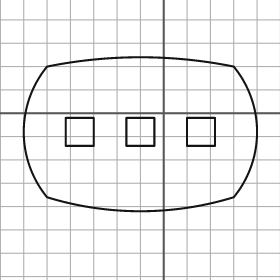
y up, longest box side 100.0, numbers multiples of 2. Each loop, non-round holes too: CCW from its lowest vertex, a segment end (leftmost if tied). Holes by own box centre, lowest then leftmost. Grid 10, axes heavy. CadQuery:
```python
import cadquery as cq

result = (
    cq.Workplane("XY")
    .moveTo(-50.0, -36.0)
    .threePointArc((-10.0, -42.0), (30.0, -36.0))
    .threePointArc((40.0, -8.0), (30.0, 20.0))
    .threePointArc((-10.0, 24.0), (-50.0, 20.0))
    .threePointArc((-60.0, -8.0), (-50.0, -36.0))
    .close()
    .moveTo(-42.0, -14.0)
    .lineTo(-30.0, -14.0)
    .lineTo(-30.0, -2.0)
    .lineTo(-42.0, -2.0)
    .close()
    .moveTo(-16.0, -14.0)
    .lineTo(-4.0, -14.0)
    .lineTo(-4.0, -2.0)
    .lineTo(-16.0, -2.0)
    .close()
    .moveTo(10.0, -14.0)
    .lineTo(22.0, -14.0)
    .lineTo(22.0, -2.0)
    .lineTo(10.0, -2.0)
    .close()
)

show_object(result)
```